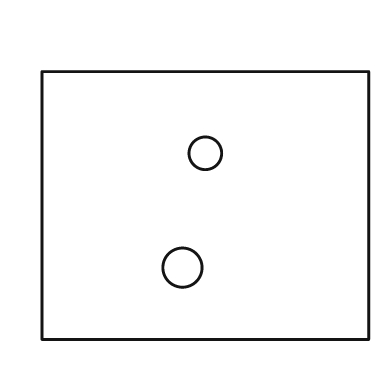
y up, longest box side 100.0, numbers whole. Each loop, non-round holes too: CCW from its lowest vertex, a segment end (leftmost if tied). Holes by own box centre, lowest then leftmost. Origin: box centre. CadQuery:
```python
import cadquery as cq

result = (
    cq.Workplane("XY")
    .moveTo(-50.0, -41.0)
    .lineTo(50.0, -41.0)
    .lineTo(50.0, 41.0)
    .lineTo(-50.0, 41.0)
    .close()
    .moveTo(-7.0, -19.0)
    .circle(6.0)
    .moveTo(0.0, 16.0)
    .circle(5.0)
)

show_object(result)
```